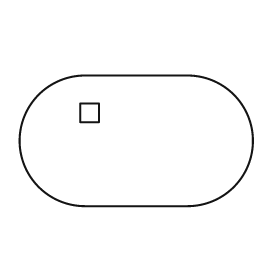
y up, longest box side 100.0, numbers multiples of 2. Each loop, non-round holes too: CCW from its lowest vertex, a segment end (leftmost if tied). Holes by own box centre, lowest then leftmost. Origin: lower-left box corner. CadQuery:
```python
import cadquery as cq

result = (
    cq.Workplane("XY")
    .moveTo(28.0, 0.0)
    .lineTo(72.0, 0.0)
    .threePointArc((100.0, 28.0), (72.0, 56.0))
    .lineTo(28.0, 56.0)
    .threePointArc((0.0, 28.0), (28.0, 0.0))
    .close()
    .moveTo(26.0, 36.0)
    .lineTo(34.0, 36.0)
    .lineTo(34.0, 44.0)
    .lineTo(26.0, 44.0)
    .close()
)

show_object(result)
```